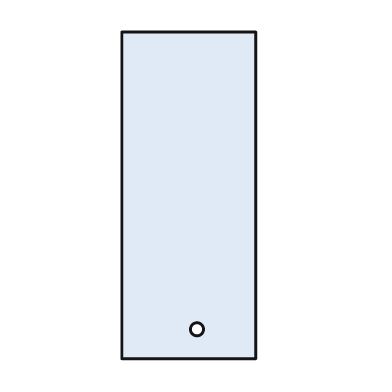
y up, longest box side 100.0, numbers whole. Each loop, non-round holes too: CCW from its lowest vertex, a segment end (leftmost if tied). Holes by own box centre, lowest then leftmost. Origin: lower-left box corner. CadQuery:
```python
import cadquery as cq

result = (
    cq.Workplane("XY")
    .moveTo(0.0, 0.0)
    .lineTo(41.0, 0.0)
    .lineTo(41.0, 100.0)
    .lineTo(0.0, 100.0)
    .close()
    .moveTo(23.0, 9.0)
    .circle(2.0)
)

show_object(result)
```